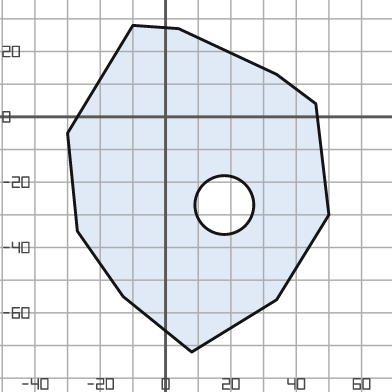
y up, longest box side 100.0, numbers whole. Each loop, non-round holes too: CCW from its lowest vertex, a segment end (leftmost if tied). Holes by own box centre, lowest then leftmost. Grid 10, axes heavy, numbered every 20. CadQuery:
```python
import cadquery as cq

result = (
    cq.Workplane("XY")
    .moveTo(8.0, -72.0)
    .lineTo(34.0, -56.0)
    .lineTo(50.0, -30.0)
    .lineTo(46.0, 4.0)
    .lineTo(34.0, 13.0)
    .lineTo(4.0, 27.0)
    .lineTo(-10.0, 28.0)
    .lineTo(-30.0, -5.0)
    .lineTo(-27.0, -35.0)
    .lineTo(-13.0, -55.0)
    .close()
    .moveTo(18.0, -27.0)
    .circle(9.0)
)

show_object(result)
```